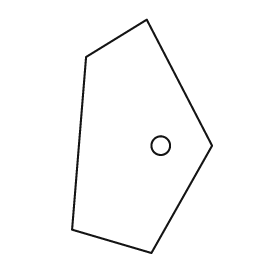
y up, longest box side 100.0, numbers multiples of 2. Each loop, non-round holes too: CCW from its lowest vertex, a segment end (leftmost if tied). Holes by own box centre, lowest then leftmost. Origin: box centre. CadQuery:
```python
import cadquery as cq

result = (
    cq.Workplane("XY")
    .moveTo(4.0, -50.0)
    .lineTo(30.0, -4.0)
    .lineTo(2.0, 50.0)
    .lineTo(-24.0, 34.0)
    .lineTo(-30.0, -40.0)
    .close()
    .moveTo(8.0, -4.0)
    .circle(4.0)
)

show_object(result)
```